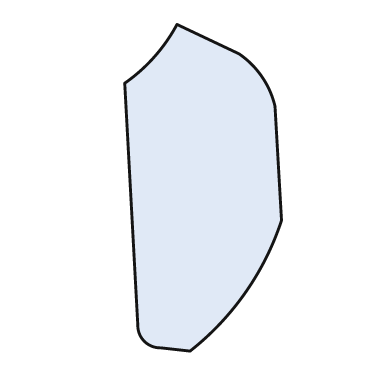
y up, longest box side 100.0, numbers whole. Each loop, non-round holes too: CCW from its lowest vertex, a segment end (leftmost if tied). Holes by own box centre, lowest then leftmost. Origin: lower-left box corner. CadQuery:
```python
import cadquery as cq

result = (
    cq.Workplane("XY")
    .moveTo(20.0, 0.0)
    .threePointArc((37.0, 18.0), (48.0, 40.0))
    .lineTo(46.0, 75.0)
    .threePointArc((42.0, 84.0), (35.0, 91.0))
    .lineTo(16.0, 100.0)
    .threePointArc((9.0, 90.0), (0.0, 82.0))
    .lineTo(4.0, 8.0)
    .threePointArc((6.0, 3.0), (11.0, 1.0))
    .close()
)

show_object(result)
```